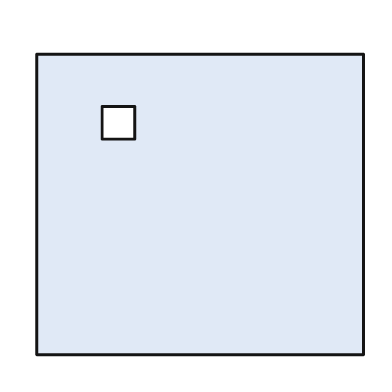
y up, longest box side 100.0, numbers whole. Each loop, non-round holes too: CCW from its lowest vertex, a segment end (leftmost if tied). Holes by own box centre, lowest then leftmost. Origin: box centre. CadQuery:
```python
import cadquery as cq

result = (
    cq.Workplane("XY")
    .moveTo(-50.0, -46.0)
    .lineTo(50.0, -46.0)
    .lineTo(50.0, 46.0)
    .lineTo(-50.0, 46.0)
    .close()
    .moveTo(-30.0, 20.0)
    .lineTo(-20.0, 20.0)
    .lineTo(-20.0, 30.0)
    .lineTo(-30.0, 30.0)
    .close()
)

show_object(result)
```